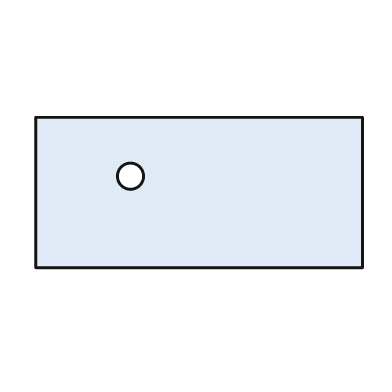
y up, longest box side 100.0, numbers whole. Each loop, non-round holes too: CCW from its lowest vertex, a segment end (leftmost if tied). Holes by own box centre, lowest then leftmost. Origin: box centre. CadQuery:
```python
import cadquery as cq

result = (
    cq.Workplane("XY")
    .moveTo(-50.0, -23.0)
    .lineTo(50.0, -23.0)
    .lineTo(50.0, 23.0)
    .lineTo(-50.0, 23.0)
    .close()
    .moveTo(-21.0, 5.0)
    .circle(4.0)
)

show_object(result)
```